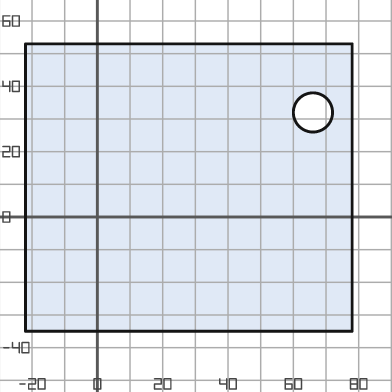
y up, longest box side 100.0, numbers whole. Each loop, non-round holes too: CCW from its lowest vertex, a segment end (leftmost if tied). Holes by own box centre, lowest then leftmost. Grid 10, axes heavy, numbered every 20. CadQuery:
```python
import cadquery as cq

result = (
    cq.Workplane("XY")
    .moveTo(-22.0, -35.0)
    .lineTo(78.0, -35.0)
    .lineTo(78.0, 53.0)
    .lineTo(-22.0, 53.0)
    .close()
    .moveTo(66.0, 32.0)
    .circle(6.0)
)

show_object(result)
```